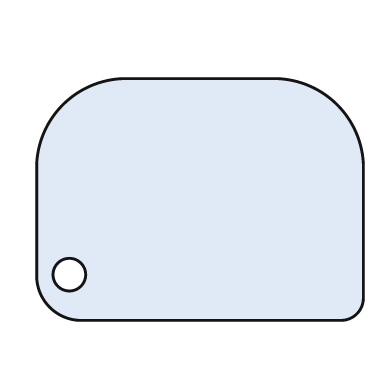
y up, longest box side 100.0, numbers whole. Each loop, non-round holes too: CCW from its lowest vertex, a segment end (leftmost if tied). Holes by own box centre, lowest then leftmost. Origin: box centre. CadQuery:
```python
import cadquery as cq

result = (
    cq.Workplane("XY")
    .moveTo(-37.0, -37.0)
    .lineTo(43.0, -37.0)
    .threePointArc((48.0, -35.0), (50.0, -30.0))
    .lineTo(50.0, 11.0)
    .threePointArc((42.0, 29.0), (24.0, 37.0))
    .lineTo(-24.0, 37.0)
    .threePointArc((-42.0, 29.0), (-50.0, 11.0))
    .lineTo(-50.0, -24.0)
    .threePointArc((-46.0, -33.0), (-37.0, -37.0))
    .close()
    .moveTo(-40.0, -23.0)
    .circle(5.0)
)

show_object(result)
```